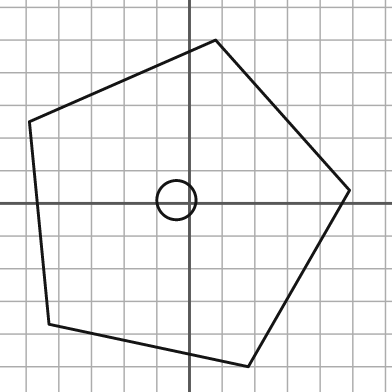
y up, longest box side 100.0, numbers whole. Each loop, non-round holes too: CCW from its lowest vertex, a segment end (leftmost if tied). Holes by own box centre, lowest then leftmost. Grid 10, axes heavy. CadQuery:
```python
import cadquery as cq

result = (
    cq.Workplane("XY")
    .moveTo(18.0, -50.0)
    .lineTo(49.0, 4.0)
    .lineTo(8.0, 50.0)
    .lineTo(-49.0, 25.0)
    .lineTo(-43.0, -37.0)
    .close()
    .moveTo(-4.0, 1.0)
    .circle(6.0)
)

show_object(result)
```